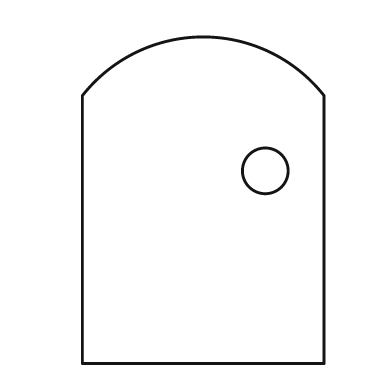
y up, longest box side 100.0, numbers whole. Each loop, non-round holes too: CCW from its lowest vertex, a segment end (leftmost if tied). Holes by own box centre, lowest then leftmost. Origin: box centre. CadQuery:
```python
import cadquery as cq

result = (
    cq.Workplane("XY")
    .moveTo(-37.0, -50.0)
    .lineTo(37.0, -50.0)
    .lineTo(37.0, 32.0)
    .threePointArc((0.0, 50.0), (-37.0, 32.0))
    .close()
    .moveTo(19.0, 9.0)
    .circle(7.0)
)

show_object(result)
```